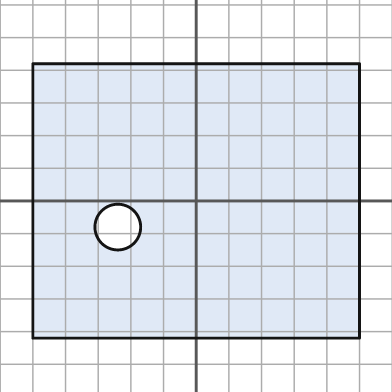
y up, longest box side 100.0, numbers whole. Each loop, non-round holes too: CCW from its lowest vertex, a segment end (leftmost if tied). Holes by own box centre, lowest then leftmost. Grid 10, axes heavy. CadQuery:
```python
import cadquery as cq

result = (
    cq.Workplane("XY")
    .moveTo(-50.0, -42.0)
    .lineTo(50.0, -42.0)
    .lineTo(50.0, 42.0)
    .lineTo(-50.0, 42.0)
    .close()
    .moveTo(-24.0, -8.0)
    .circle(7.0)
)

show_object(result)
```